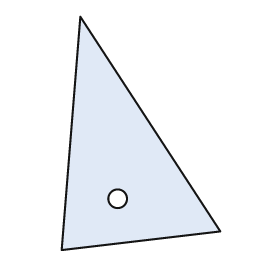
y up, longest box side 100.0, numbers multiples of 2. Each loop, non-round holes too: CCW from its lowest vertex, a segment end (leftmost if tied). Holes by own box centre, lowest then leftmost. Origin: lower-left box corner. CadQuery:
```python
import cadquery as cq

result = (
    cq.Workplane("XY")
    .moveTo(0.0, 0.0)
    .lineTo(68.0, 8.0)
    .lineTo(8.0, 100.0)
    .close()
    .moveTo(24.0, 22.0)
    .circle(4.0)
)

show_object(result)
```